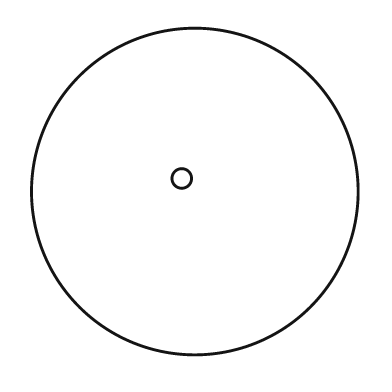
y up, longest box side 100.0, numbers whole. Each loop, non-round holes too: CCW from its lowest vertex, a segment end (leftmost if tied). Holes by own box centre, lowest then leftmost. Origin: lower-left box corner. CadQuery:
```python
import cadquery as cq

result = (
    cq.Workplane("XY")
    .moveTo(50.0, 50.0)
    .circle(50.0)
    .moveTo(46.0, 54.0)
    .circle(3.0)
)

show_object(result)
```